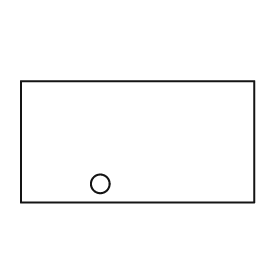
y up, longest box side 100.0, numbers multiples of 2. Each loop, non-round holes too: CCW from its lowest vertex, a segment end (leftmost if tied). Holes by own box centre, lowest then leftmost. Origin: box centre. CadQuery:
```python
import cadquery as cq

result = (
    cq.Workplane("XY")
    .moveTo(-50.0, -26.0)
    .lineTo(50.0, -26.0)
    .lineTo(50.0, 26.0)
    .lineTo(-50.0, 26.0)
    .close()
    .moveTo(-16.0, -18.0)
    .circle(4.0)
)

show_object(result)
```